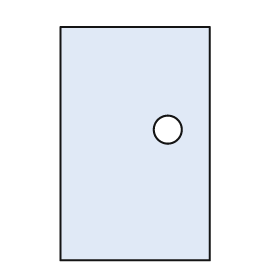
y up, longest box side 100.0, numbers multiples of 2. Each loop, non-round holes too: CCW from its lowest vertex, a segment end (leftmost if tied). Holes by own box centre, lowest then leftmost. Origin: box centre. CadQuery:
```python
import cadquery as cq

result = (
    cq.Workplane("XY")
    .moveTo(-32.0, -50.0)
    .lineTo(32.0, -50.0)
    .lineTo(32.0, 50.0)
    .lineTo(-32.0, 50.0)
    .close()
    .moveTo(14.0, 6.0)
    .circle(6.0)
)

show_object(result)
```